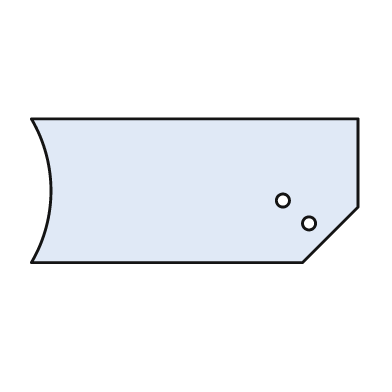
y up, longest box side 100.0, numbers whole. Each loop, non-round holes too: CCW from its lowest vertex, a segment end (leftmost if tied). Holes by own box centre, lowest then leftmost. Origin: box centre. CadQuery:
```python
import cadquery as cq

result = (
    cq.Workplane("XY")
    .moveTo(-50.0, -22.0)
    .lineTo(33.0, -22.0)
    .lineTo(50.0, -5.0)
    .lineTo(50.0, 22.0)
    .lineTo(-50.0, 22.0)
    .threePointArc((-44.0, 0.0), (-50.0, -22.0))
    .close()
    .moveTo(35.0, -10.0)
    .circle(2.0)
    .moveTo(27.0, -3.0)
    .circle(2.0)
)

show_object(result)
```